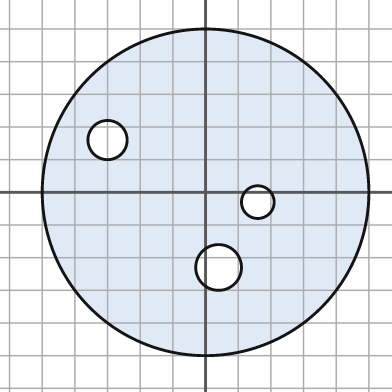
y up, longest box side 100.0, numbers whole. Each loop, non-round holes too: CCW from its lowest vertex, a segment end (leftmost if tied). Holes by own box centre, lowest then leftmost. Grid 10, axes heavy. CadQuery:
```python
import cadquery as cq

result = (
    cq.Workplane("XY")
    .moveTo(0.0, 0.0)
    .circle(50.0)
    .moveTo(4.0, -23.0)
    .circle(7.0)
    .moveTo(16.0, -3.0)
    .circle(5.0)
    .moveTo(-30.0, 16.0)
    .circle(6.0)
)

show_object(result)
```